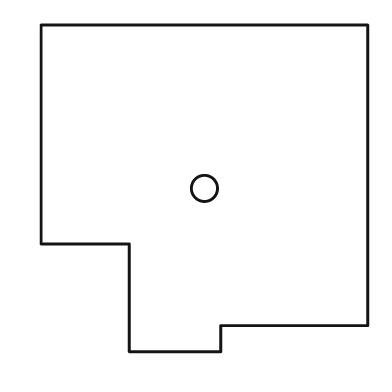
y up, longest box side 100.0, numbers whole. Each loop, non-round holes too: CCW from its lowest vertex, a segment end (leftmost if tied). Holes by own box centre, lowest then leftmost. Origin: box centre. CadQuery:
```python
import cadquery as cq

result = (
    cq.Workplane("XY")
    .moveTo(-23.0, -50.0)
    .lineTo(5.0, -50.0)
    .lineTo(5.0, -42.0)
    .lineTo(50.0, -42.0)
    .lineTo(50.0, 50.0)
    .lineTo(-50.0, 50.0)
    .lineTo(-50.0, -17.0)
    .lineTo(-23.0, -17.0)
    .close()
    .moveTo(0.0, 0.0)
    .circle(4.0)
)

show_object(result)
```